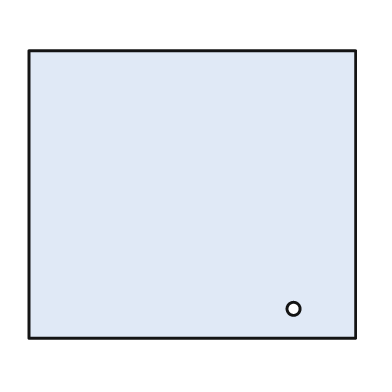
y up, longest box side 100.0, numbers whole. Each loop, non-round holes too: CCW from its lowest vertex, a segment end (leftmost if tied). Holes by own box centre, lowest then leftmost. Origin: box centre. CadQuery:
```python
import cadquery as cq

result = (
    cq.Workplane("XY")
    .moveTo(-50.0, -44.0)
    .lineTo(50.0, -44.0)
    .lineTo(50.0, 44.0)
    .lineTo(-50.0, 44.0)
    .close()
    .moveTo(31.0, -35.0)
    .circle(2.0)
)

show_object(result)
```